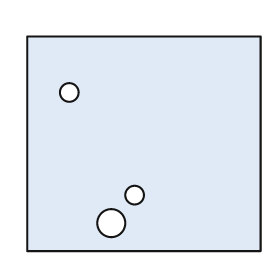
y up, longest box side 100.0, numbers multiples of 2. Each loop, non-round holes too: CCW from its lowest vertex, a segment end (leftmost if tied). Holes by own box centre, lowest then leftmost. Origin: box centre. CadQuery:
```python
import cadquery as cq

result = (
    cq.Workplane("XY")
    .moveTo(-50.0, -46.0)
    .lineTo(50.0, -46.0)
    .lineTo(50.0, 46.0)
    .lineTo(-50.0, 46.0)
    .close()
    .moveTo(-14.0, -34.0)
    .circle(6.0)
    .moveTo(-4.0, -22.0)
    .circle(4.0)
    .moveTo(-32.0, 22.0)
    .circle(4.0)
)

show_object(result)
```